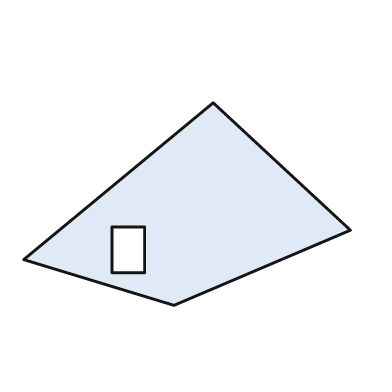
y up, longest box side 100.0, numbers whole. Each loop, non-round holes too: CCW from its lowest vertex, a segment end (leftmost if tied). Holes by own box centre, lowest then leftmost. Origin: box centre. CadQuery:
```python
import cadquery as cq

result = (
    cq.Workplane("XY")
    .moveTo(-4.0, -31.0)
    .lineTo(50.0, -8.0)
    .lineTo(8.0, 31.0)
    .lineTo(-50.0, -17.0)
    .close()
    .moveTo(-23.0, -21.0)
    .lineTo(-13.0, -21.0)
    .lineTo(-13.0, -7.0)
    .lineTo(-23.0, -7.0)
    .close()
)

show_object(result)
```